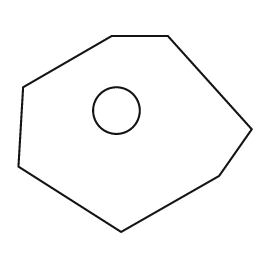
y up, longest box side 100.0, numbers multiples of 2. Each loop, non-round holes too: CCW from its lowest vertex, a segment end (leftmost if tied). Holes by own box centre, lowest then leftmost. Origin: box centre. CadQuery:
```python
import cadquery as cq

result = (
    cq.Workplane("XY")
    .moveTo(-6.0, -42.0)
    .lineTo(36.0, -18.0)
    .lineTo(50.0, 2.0)
    .lineTo(14.0, 42.0)
    .lineTo(-10.0, 42.0)
    .lineTo(-48.0, 20.0)
    .lineTo(-50.0, -14.0)
    .close()
    .moveTo(-8.0, 10.0)
    .circle(10.0)
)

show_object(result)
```